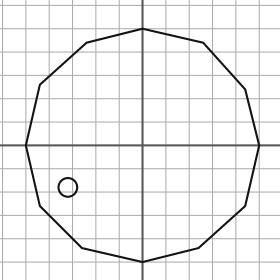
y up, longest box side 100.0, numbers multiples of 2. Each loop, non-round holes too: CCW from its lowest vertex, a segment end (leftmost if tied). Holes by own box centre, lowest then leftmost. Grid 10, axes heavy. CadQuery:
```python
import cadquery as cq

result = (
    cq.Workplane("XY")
    .moveTo(0.0, -50.0)
    .lineTo(24.0, -44.0)
    .lineTo(44.0, -26.0)
    .lineTo(50.0, 0.0)
    .lineTo(44.0, 24.0)
    .lineTo(26.0, 44.0)
    .lineTo(0.0, 50.0)
    .lineTo(-24.0, 44.0)
    .lineTo(-44.0, 26.0)
    .lineTo(-50.0, 0.0)
    .lineTo(-44.0, -26.0)
    .lineTo(-26.0, -44.0)
    .close()
    .moveTo(-32.0, -18.0)
    .circle(4.0)
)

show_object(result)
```